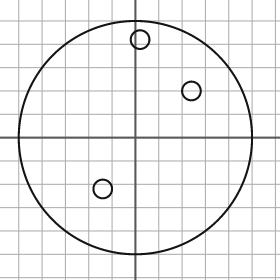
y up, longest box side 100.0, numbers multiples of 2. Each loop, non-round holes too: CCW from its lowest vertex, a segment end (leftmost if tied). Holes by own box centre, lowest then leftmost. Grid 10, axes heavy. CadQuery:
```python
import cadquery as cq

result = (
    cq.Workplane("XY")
    .moveTo(0.0, 0.0)
    .circle(50.0)
    .moveTo(-14.0, -22.0)
    .circle(4.0)
    .moveTo(24.0, 20.0)
    .circle(4.0)
    .moveTo(2.0, 42.0)
    .circle(4.0)
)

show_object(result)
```